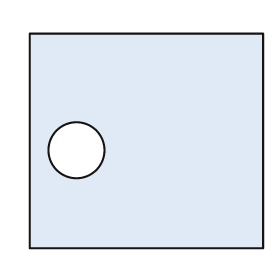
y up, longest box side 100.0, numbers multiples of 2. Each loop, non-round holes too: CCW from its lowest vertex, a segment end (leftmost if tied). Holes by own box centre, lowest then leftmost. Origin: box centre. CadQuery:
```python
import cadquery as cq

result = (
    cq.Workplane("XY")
    .moveTo(-50.0, -46.0)
    .lineTo(50.0, -46.0)
    .lineTo(50.0, 46.0)
    .lineTo(-50.0, 46.0)
    .close()
    .moveTo(-30.0, -4.0)
    .circle(12.0)
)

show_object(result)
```